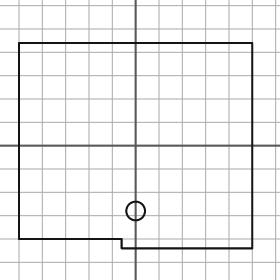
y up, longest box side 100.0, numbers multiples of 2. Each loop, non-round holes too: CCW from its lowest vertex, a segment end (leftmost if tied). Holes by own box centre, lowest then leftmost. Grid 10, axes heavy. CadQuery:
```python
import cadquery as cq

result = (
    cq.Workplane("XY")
    .moveTo(-6.0, -44.0)
    .lineTo(50.0, -44.0)
    .lineTo(50.0, 44.0)
    .lineTo(-50.0, 44.0)
    .lineTo(-50.0, -40.0)
    .lineTo(-6.0, -40.0)
    .close()
    .moveTo(0.0, -28.0)
    .circle(4.0)
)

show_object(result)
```